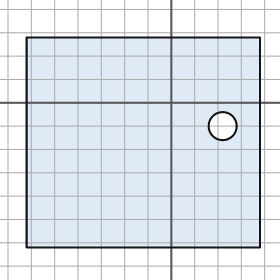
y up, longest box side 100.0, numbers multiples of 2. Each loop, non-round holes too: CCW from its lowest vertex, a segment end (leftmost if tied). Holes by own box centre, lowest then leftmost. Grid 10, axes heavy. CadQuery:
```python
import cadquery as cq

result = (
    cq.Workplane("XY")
    .moveTo(-62.0, -62.0)
    .lineTo(38.0, -62.0)
    .lineTo(38.0, 28.0)
    .lineTo(-62.0, 28.0)
    .close()
    .moveTo(22.0, -10.0)
    .circle(6.0)
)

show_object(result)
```